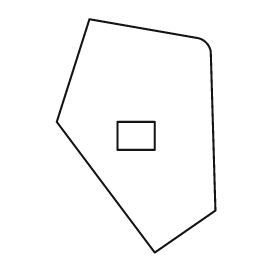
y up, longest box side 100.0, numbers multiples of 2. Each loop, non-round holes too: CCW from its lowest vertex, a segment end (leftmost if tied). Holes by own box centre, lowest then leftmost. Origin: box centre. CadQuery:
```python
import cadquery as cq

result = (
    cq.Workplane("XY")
    .moveTo(8.0, -50.0)
    .lineTo(34.0, -32.0)
    .lineTo(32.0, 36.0)
    .threePointArc((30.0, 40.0), (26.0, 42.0))
    .lineTo(-20.0, 50.0)
    .lineTo(-34.0, 6.0)
    .close()
    .moveTo(-8.0, -6.0)
    .lineTo(8.0, -6.0)
    .lineTo(8.0, 6.0)
    .lineTo(-8.0, 6.0)
    .close()
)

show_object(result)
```